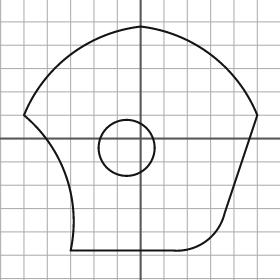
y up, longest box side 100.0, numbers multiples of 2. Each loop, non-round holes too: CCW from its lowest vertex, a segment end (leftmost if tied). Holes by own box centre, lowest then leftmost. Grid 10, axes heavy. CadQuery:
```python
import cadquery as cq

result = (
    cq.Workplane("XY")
    .moveTo(-30.0, -48.0)
    .lineTo(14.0, -48.0)
    .threePointArc((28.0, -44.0), (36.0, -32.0))
    .lineTo(50.0, 10.0)
    .threePointArc((30.0, 36.0), (0.0, 48.0))
    .threePointArc((-30.0, 36.0), (-50.0, 10.0))
    .threePointArc((-32.0, -16.0), (-30.0, -48.0))
    .close()
    .moveTo(-6.0, -4.0)
    .circle(12.0)
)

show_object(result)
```